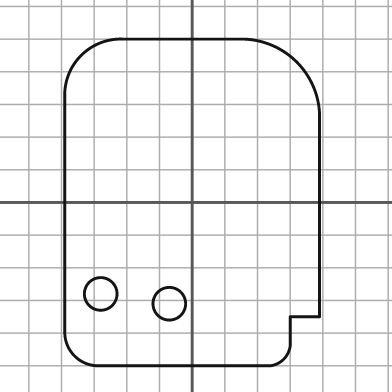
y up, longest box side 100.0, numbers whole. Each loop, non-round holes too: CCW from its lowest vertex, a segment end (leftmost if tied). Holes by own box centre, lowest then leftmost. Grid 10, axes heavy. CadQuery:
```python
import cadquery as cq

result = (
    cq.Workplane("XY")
    .moveTo(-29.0, -50.0)
    .lineTo(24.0, -50.0)
    .threePointArc((28.0, -48.0), (30.0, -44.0))
    .lineTo(30.0, -35.0)
    .lineTo(39.0, -35.0)
    .lineTo(39.0, 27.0)
    .threePointArc((32.0, 43.0), (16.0, 50.0))
    .lineTo(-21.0, 50.0)
    .threePointArc((-34.0, 45.0), (-39.0, 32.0))
    .lineTo(-39.0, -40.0)
    .threePointArc((-36.0, -47.0), (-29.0, -50.0))
    .close()
    .moveTo(-7.0, -31.0)
    .circle(5.0)
    .moveTo(-28.0, -28.0)
    .circle(5.0)
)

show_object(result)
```